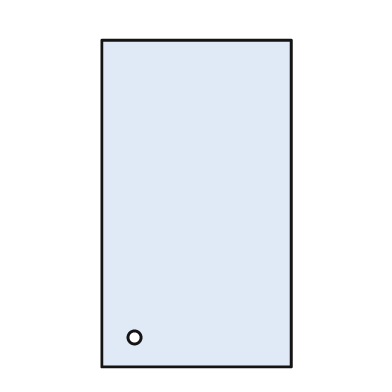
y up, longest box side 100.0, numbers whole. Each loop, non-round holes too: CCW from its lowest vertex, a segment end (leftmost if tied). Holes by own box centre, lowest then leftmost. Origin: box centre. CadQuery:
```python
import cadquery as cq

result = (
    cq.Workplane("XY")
    .moveTo(-29.0, -50.0)
    .lineTo(29.0, -50.0)
    .lineTo(29.0, 50.0)
    .lineTo(-29.0, 50.0)
    .close()
    .moveTo(-19.0, -41.0)
    .circle(2.0)
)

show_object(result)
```